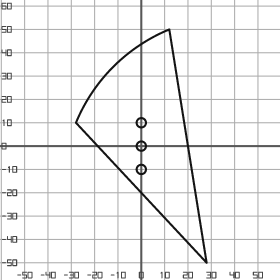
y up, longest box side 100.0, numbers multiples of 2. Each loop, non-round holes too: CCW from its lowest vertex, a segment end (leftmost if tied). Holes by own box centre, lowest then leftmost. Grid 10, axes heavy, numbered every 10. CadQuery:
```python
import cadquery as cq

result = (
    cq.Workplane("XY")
    .moveTo(28.0, -50.0)
    .lineTo(12.0, 50.0)
    .threePointArc((-12.0, 34.0), (-28.0, 10.0))
    .close()
    .moveTo(0.0, -10.0)
    .circle(2.0)
    .moveTo(0.0, 0.0)
    .circle(2.0)
    .moveTo(0.0, 10.0)
    .circle(2.0)
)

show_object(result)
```